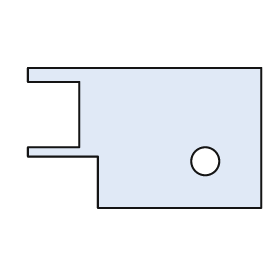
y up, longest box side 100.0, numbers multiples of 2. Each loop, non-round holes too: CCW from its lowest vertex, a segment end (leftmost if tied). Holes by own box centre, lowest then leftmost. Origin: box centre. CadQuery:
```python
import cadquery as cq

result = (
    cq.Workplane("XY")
    .moveTo(-20.0, -30.0)
    .lineTo(50.0, -30.0)
    .lineTo(50.0, 30.0)
    .lineTo(-50.0, 30.0)
    .lineTo(-50.0, 24.0)
    .lineTo(-28.0, 24.0)
    .lineTo(-28.0, -4.0)
    .lineTo(-50.0, -4.0)
    .lineTo(-50.0, -8.0)
    .lineTo(-20.0, -8.0)
    .close()
    .moveTo(26.0, -10.0)
    .circle(6.0)
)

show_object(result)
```